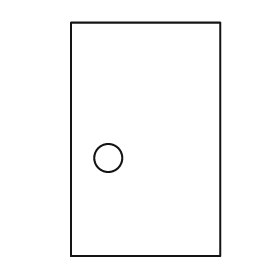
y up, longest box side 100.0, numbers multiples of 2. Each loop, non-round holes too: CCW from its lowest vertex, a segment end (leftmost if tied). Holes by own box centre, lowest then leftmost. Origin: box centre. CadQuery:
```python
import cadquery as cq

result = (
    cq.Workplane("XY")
    .moveTo(-32.0, -50.0)
    .lineTo(32.0, -50.0)
    .lineTo(32.0, 50.0)
    .lineTo(-32.0, 50.0)
    .close()
    .moveTo(-16.0, -8.0)
    .circle(6.0)
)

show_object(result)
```